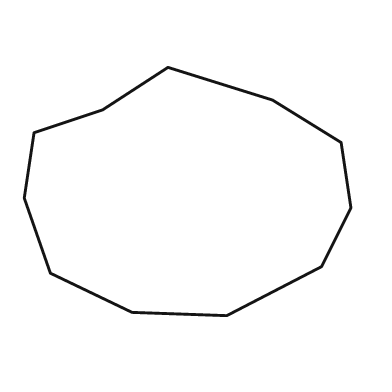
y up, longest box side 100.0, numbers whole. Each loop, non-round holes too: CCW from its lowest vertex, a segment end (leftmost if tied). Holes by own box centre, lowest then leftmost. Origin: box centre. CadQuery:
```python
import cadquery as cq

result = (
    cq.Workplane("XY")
    .moveTo(12.0, -38.0)
    .lineTo(41.0, -23.0)
    .lineTo(50.0, -5.0)
    .lineTo(47.0, 15.0)
    .lineTo(26.0, 28.0)
    .lineTo(-6.0, 38.0)
    .lineTo(-26.0, 25.0)
    .lineTo(-47.0, 18.0)
    .lineTo(-50.0, -2.0)
    .lineTo(-42.0, -25.0)
    .lineTo(-17.0, -37.0)
    .close()
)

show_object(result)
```